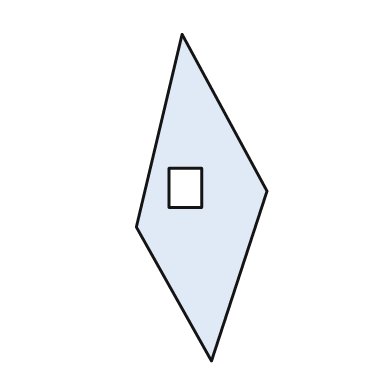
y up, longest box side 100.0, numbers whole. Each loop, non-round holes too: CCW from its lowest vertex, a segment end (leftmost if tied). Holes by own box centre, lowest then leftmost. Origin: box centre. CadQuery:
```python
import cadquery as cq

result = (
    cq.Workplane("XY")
    .moveTo(3.0, -50.0)
    .lineTo(20.0, 2.0)
    .lineTo(-6.0, 50.0)
    .lineTo(-20.0, -9.0)
    .close()
    .moveTo(-10.0, -3.0)
    .lineTo(0.0, -3.0)
    .lineTo(0.0, 9.0)
    .lineTo(-10.0, 9.0)
    .close()
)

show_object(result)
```